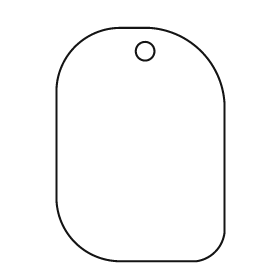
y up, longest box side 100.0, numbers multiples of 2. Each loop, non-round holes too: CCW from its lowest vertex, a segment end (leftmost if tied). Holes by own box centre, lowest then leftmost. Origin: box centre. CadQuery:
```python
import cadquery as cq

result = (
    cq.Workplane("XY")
    .moveTo(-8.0, -50.0)
    .lineTo(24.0, -50.0)
    .threePointArc((32.0, -46.0), (36.0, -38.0))
    .lineTo(36.0, 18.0)
    .threePointArc((26.0, 40.0), (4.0, 50.0))
    .lineTo(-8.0, 50.0)
    .threePointArc((-28.0, 42.0), (-36.0, 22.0))
    .lineTo(-36.0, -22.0)
    .threePointArc((-28.0, -42.0), (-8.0, -50.0))
    .close()
    .moveTo(2.0, 40.0)
    .circle(4.0)
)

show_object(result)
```